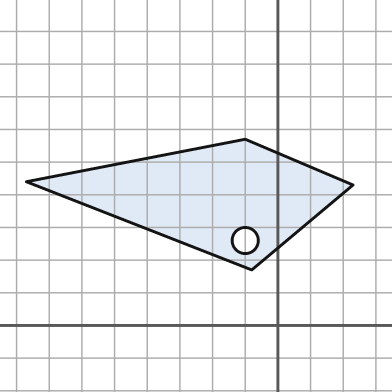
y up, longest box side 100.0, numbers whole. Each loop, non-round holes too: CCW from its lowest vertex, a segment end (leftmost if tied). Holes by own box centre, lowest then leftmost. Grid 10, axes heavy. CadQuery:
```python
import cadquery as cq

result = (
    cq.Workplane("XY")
    .moveTo(-8.0, 17.0)
    .lineTo(23.0, 43.0)
    .lineTo(-10.0, 57.0)
    .lineTo(-77.0, 44.0)
    .close()
    .moveTo(-10.0, 26.0)
    .circle(4.0)
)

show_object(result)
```